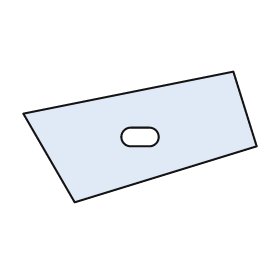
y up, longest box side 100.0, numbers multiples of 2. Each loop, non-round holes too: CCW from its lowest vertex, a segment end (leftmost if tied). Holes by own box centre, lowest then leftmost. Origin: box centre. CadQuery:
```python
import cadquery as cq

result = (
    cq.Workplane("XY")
    .moveTo(-28.0, -28.0)
    .lineTo(50.0, -4.0)
    .lineTo(40.0, 28.0)
    .lineTo(-50.0, 10.0)
    .close()
    .moveTo(-4.0, -4.0)
    .lineTo(4.0, -4.0)
    .threePointArc((8.0, 0.0), (4.0, 4.0))
    .lineTo(-4.0, 4.0)
    .threePointArc((-8.0, 0.0), (-4.0, -4.0))
    .close()
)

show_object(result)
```